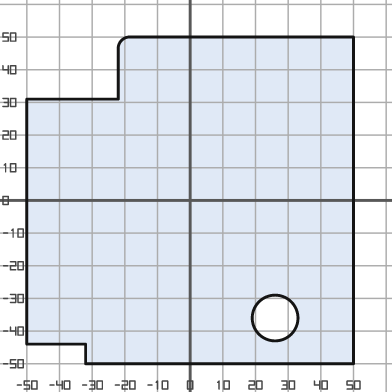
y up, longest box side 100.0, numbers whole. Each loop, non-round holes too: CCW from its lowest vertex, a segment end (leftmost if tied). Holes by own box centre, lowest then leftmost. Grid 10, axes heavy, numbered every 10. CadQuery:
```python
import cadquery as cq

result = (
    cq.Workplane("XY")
    .moveTo(-32.0, -50.0)
    .lineTo(50.0, -50.0)
    .lineTo(50.0, 50.0)
    .lineTo(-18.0, 50.0)
    .threePointArc((-21.0, 49.0), (-22.0, 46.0))
    .lineTo(-22.0, 31.0)
    .lineTo(-50.0, 31.0)
    .lineTo(-50.0, -44.0)
    .lineTo(-32.0, -44.0)
    .close()
    .moveTo(26.0, -36.0)
    .circle(7.0)
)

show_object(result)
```